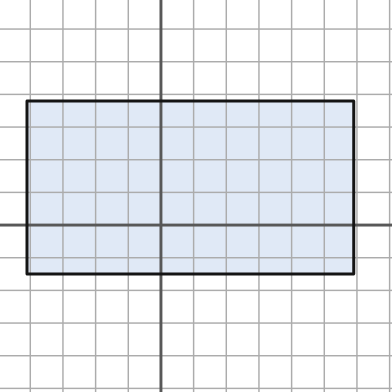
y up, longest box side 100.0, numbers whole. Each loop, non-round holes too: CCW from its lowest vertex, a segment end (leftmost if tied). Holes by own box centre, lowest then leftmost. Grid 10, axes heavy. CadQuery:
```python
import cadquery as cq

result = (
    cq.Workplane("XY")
    .moveTo(-41.0, -15.0)
    .lineTo(59.0, -15.0)
    .lineTo(59.0, 38.0)
    .lineTo(-41.0, 38.0)
    .close()
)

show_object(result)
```